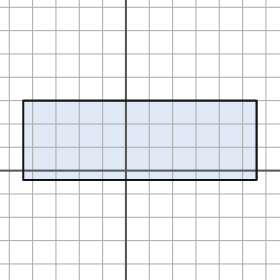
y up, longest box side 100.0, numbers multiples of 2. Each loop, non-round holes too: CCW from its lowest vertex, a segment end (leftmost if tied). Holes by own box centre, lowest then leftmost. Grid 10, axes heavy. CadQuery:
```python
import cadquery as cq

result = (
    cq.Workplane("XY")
    .moveTo(-44.0, -4.0)
    .lineTo(56.0, -4.0)
    .lineTo(56.0, 30.0)
    .lineTo(-44.0, 30.0)
    .close()
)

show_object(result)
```